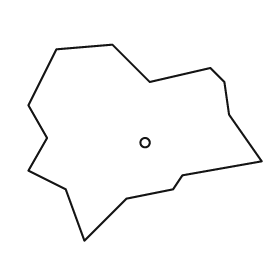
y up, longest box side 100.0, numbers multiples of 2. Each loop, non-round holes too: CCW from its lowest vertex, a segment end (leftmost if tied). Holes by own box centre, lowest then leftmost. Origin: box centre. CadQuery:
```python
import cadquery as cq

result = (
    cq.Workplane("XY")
    .moveTo(-26.0, -42.0)
    .lineTo(-8.0, -24.0)
    .lineTo(12.0, -20.0)
    .lineTo(16.0, -14.0)
    .lineTo(50.0, -8.0)
    .lineTo(36.0, 12.0)
    .lineTo(34.0, 26.0)
    .lineTo(28.0, 32.0)
    .lineTo(2.0, 26.0)
    .lineTo(-14.0, 42.0)
    .lineTo(-38.0, 40.0)
    .lineTo(-50.0, 16.0)
    .lineTo(-42.0, 2.0)
    .lineTo(-50.0, -12.0)
    .lineTo(-34.0, -20.0)
    .close()
    .moveTo(0.0, 0.0)
    .circle(2.0)
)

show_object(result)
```